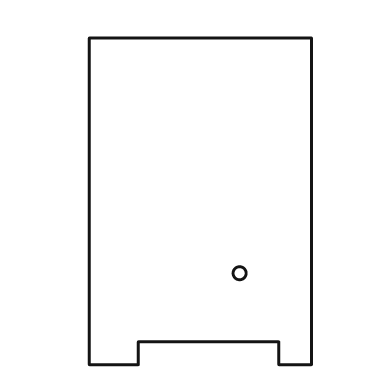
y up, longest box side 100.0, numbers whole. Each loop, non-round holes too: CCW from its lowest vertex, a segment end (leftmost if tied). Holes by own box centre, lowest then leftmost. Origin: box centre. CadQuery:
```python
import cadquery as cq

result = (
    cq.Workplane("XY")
    .moveTo(-34.0, -50.0)
    .lineTo(-19.0, -50.0)
    .lineTo(-19.0, -43.0)
    .lineTo(24.0, -43.0)
    .lineTo(24.0, -50.0)
    .lineTo(34.0, -50.0)
    .lineTo(34.0, 50.0)
    .lineTo(-34.0, 50.0)
    .close()
    .moveTo(12.0, -22.0)
    .circle(2.0)
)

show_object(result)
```